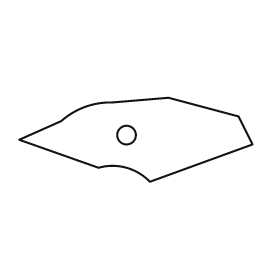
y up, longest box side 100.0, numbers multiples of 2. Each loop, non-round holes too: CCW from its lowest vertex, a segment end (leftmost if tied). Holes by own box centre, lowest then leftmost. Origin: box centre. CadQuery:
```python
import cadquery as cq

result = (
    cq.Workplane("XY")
    .moveTo(6.0, -18.0)
    .lineTo(50.0, -2.0)
    .lineTo(44.0, 10.0)
    .lineTo(14.0, 18.0)
    .lineTo(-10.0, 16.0)
    .threePointArc((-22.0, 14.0), (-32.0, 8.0))
    .lineTo(-50.0, 0.0)
    .lineTo(-16.0, -12.0)
    .threePointArc((-4.0, -12.0), (6.0, -18.0))
    .close()
    .moveTo(-4.0, 2.0)
    .circle(4.0)
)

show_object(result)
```